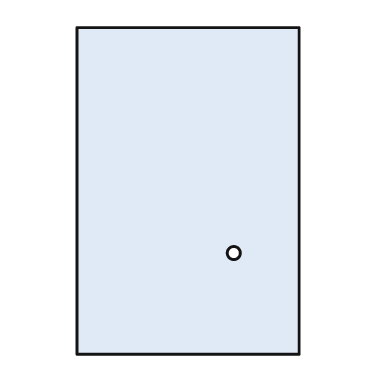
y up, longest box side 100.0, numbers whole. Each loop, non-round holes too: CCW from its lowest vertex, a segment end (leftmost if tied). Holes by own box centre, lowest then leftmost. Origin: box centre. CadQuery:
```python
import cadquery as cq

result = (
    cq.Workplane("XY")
    .moveTo(-34.0, -50.0)
    .lineTo(34.0, -50.0)
    .lineTo(34.0, 50.0)
    .lineTo(-34.0, 50.0)
    .close()
    .moveTo(14.0, -19.0)
    .circle(2.0)
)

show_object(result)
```